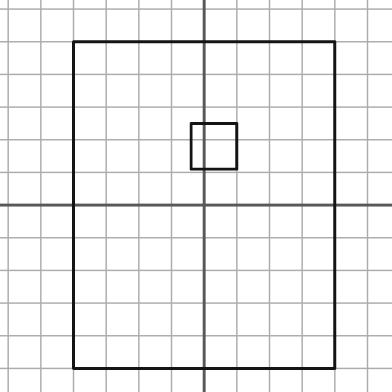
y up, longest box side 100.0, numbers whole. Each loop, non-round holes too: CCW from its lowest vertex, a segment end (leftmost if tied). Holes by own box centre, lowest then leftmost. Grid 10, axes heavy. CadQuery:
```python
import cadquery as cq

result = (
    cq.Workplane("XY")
    .moveTo(-40.0, -50.0)
    .lineTo(40.0, -50.0)
    .lineTo(40.0, 50.0)
    .lineTo(-40.0, 50.0)
    .close()
    .moveTo(-4.0, 11.0)
    .lineTo(10.0, 11.0)
    .lineTo(10.0, 25.0)
    .lineTo(-4.0, 25.0)
    .close()
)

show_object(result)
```